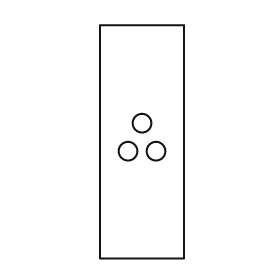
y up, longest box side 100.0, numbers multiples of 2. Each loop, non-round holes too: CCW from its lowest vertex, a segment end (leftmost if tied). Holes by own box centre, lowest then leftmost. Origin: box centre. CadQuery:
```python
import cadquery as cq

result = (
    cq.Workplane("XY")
    .moveTo(-18.0, -50.0)
    .lineTo(18.0, -50.0)
    .lineTo(18.0, 50.0)
    .lineTo(-18.0, 50.0)
    .close()
    .moveTo(-6.0, -4.0)
    .circle(4.0)
    .moveTo(6.0, -4.0)
    .circle(4.0)
    .moveTo(0.0, 8.0)
    .circle(4.0)
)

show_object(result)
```